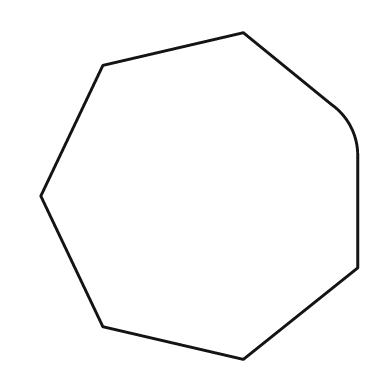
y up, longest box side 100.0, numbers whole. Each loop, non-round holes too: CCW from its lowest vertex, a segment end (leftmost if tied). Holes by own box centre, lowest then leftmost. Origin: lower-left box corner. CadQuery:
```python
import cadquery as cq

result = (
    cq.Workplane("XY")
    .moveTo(62.0, 0.0)
    .lineTo(97.0, 28.0)
    .lineTo(97.0, 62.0)
    .threePointArc((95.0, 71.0), (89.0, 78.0))
    .lineTo(62.0, 100.0)
    .lineTo(19.0, 90.0)
    .lineTo(0.0, 50.0)
    .lineTo(19.0, 10.0)
    .close()
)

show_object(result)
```